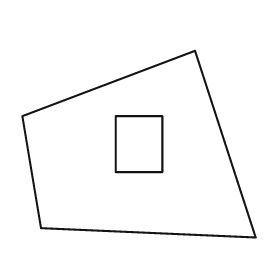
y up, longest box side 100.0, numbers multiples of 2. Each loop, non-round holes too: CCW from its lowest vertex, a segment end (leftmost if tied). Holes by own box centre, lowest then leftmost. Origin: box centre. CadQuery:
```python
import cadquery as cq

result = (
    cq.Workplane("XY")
    .moveTo(50.0, -40.0)
    .lineTo(24.0, 40.0)
    .lineTo(-50.0, 12.0)
    .lineTo(-42.0, -36.0)
    .close()
    .moveTo(-10.0, -12.0)
    .lineTo(10.0, -12.0)
    .lineTo(10.0, 12.0)
    .lineTo(-10.0, 12.0)
    .close()
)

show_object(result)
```